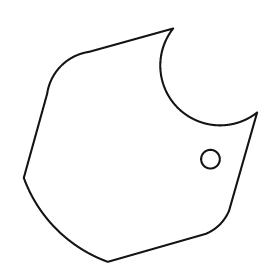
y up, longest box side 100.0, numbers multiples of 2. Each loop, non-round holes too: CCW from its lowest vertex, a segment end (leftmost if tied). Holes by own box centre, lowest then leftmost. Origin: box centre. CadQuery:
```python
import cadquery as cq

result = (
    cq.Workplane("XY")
    .moveTo(-14.0, -50.0)
    .lineTo(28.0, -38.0)
    .threePointArc((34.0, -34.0), (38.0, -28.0))
    .lineTo(50.0, 14.0)
    .threePointArc((16.0, 16.0), (14.0, 50.0))
    .lineTo(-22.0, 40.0)
    .threePointArc((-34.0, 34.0), (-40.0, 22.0))
    .lineTo(-50.0, -14.0)
    .threePointArc((-36.0, -36.0), (-14.0, -50.0))
    .close()
    .moveTo(30.0, -6.0)
    .circle(4.0)
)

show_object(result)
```